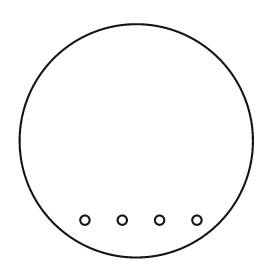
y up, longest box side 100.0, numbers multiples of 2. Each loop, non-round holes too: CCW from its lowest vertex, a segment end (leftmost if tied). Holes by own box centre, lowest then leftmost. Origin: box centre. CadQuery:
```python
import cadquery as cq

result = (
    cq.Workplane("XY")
    .moveTo(0.0, 0.0)
    .circle(50.0)
    .moveTo(-22.0, -34.0)
    .circle(2.0)
    .moveTo(-6.0, -34.0)
    .circle(2.0)
    .moveTo(10.0, -34.0)
    .circle(2.0)
    .moveTo(26.0, -34.0)
    .circle(2.0)
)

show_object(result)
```